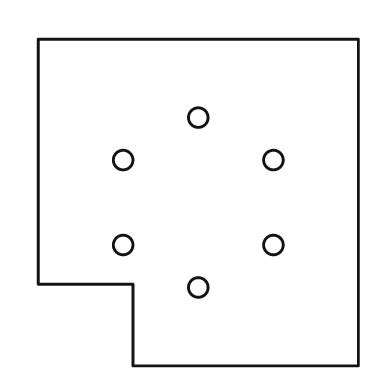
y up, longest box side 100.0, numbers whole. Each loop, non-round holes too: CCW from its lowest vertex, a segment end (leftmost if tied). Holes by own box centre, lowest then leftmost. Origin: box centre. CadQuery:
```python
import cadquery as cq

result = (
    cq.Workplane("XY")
    .moveTo(-20.0, -50.0)
    .lineTo(49.0, -50.0)
    .lineTo(49.0, 50.0)
    .lineTo(-49.0, 50.0)
    .lineTo(-49.0, -25.0)
    .lineTo(-20.0, -25.0)
    .close()
    .moveTo(0.0, -26.0)
    .circle(3.0)
    .moveTo(-23.0, -13.0)
    .circle(3.0)
    .moveTo(23.0, -13.0)
    .circle(3.0)
    .moveTo(-23.0, 13.0)
    .circle(3.0)
    .moveTo(23.0, 13.0)
    .circle(3.0)
    .moveTo(0.0, 26.0)
    .circle(3.0)
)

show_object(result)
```